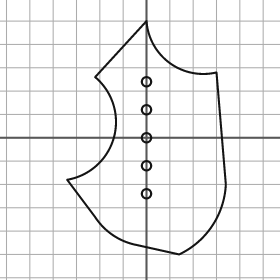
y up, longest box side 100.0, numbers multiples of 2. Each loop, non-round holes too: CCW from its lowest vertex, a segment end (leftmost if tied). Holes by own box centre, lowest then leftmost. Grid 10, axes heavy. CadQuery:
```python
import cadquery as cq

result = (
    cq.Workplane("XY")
    .moveTo(14.0, -50.0)
    .threePointArc((28.0, -38.0), (34.0, -20.0))
    .lineTo(30.0, 28.0)
    .threePointArc((10.0, 32.0), (0.0, 50.0))
    .lineTo(-22.0, 26.0)
    .threePointArc((-14.0, 0.0), (-34.0, -18.0))
    .lineTo(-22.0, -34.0)
    .threePointArc((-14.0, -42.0), (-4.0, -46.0))
    .close()
    .moveTo(0.0, -24.0)
    .circle(2.0)
    .moveTo(0.0, -12.0)
    .circle(2.0)
    .moveTo(0.0, 0.0)
    .circle(2.0)
    .moveTo(0.0, 12.0)
    .circle(2.0)
    .moveTo(0.0, 24.0)
    .circle(2.0)
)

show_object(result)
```